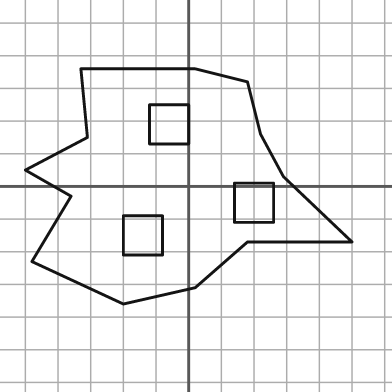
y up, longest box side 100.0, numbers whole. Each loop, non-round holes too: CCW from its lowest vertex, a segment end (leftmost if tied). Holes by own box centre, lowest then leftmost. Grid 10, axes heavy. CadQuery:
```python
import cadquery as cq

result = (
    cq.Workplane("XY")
    .moveTo(-20.0, -36.0)
    .lineTo(2.0, -31.0)
    .lineTo(18.0, -17.0)
    .lineTo(50.0, -17.0)
    .lineTo(29.0, 3.0)
    .lineTo(22.0, 16.0)
    .lineTo(18.0, 32.0)
    .lineTo(2.0, 36.0)
    .lineTo(-33.0, 36.0)
    .lineTo(-31.0, 15.0)
    .lineTo(-50.0, 5.0)
    .lineTo(-36.0, -3.0)
    .lineTo(-48.0, -23.0)
    .close()
    .moveTo(-20.0, -21.0)
    .lineTo(-8.0, -21.0)
    .lineTo(-8.0, -9.0)
    .lineTo(-20.0, -9.0)
    .close()
    .moveTo(14.0, -11.0)
    .lineTo(26.0, -11.0)
    .lineTo(26.0, 1.0)
    .lineTo(14.0, 1.0)
    .close()
    .moveTo(-12.0, 13.0)
    .lineTo(0.0, 13.0)
    .lineTo(0.0, 25.0)
    .lineTo(-12.0, 25.0)
    .close()
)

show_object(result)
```